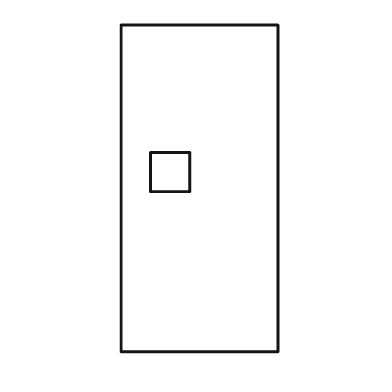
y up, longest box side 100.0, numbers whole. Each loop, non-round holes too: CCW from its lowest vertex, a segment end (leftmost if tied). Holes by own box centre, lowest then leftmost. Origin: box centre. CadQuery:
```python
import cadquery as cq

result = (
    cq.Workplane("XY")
    .moveTo(-24.0, -50.0)
    .lineTo(24.0, -50.0)
    .lineTo(24.0, 50.0)
    .lineTo(-24.0, 50.0)
    .close()
    .moveTo(-15.0, -1.0)
    .lineTo(-3.0, -1.0)
    .lineTo(-3.0, 11.0)
    .lineTo(-15.0, 11.0)
    .close()
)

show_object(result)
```